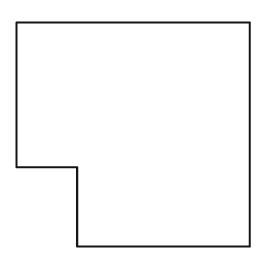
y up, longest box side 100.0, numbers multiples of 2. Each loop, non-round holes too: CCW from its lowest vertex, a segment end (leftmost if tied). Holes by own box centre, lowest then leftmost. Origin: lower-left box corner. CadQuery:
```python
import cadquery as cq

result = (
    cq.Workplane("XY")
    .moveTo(26.0, 0.0)
    .lineTo(100.0, 0.0)
    .lineTo(100.0, 96.0)
    .lineTo(0.0, 96.0)
    .lineTo(0.0, 34.0)
    .lineTo(26.0, 34.0)
    .close()
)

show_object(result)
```